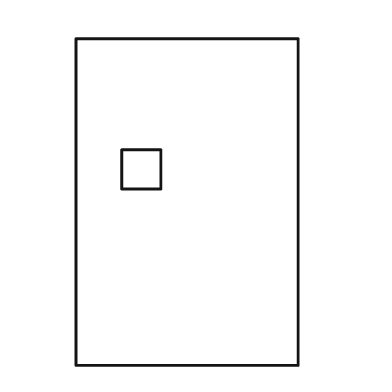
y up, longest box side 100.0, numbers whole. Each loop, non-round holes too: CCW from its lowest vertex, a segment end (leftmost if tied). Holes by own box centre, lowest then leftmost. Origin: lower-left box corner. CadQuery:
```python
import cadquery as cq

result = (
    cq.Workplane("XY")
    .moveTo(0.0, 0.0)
    .lineTo(68.0, 0.0)
    .lineTo(68.0, 100.0)
    .lineTo(0.0, 100.0)
    .close()
    .moveTo(14.0, 54.0)
    .lineTo(26.0, 54.0)
    .lineTo(26.0, 66.0)
    .lineTo(14.0, 66.0)
    .close()
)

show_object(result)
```